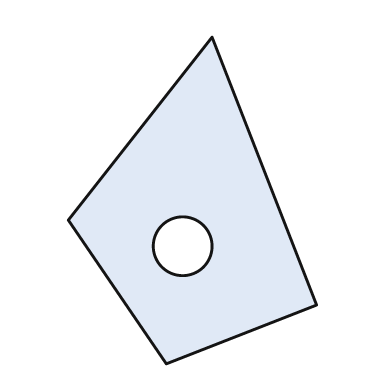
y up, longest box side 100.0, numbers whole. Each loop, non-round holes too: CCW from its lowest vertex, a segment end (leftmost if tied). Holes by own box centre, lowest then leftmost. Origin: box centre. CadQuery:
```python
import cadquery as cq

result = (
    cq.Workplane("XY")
    .moveTo(-8.0, -50.0)
    .lineTo(38.0, -32.0)
    .lineTo(6.0, 50.0)
    .lineTo(-38.0, -6.0)
    .close()
    .moveTo(-3.0, -14.0)
    .circle(9.0)
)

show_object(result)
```